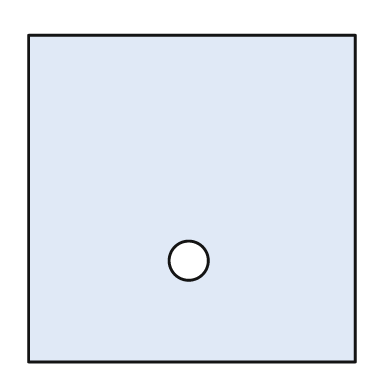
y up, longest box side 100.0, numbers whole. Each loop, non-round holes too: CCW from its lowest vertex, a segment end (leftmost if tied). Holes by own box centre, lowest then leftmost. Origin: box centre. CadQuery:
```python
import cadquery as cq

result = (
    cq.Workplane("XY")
    .moveTo(-50.0, -50.0)
    .lineTo(50.0, -50.0)
    .lineTo(50.0, 50.0)
    .lineTo(-50.0, 50.0)
    .close()
    .moveTo(-1.0, -19.0)
    .circle(6.0)
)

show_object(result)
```